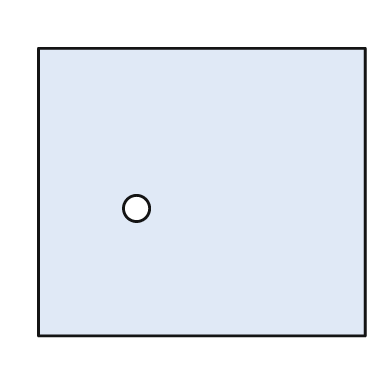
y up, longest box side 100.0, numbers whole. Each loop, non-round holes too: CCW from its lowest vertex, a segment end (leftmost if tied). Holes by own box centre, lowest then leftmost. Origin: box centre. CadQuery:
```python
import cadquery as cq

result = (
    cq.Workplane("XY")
    .moveTo(-50.0, -44.0)
    .lineTo(50.0, -44.0)
    .lineTo(50.0, 44.0)
    .lineTo(-50.0, 44.0)
    .close()
    .moveTo(-20.0, -5.0)
    .circle(4.0)
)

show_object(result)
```